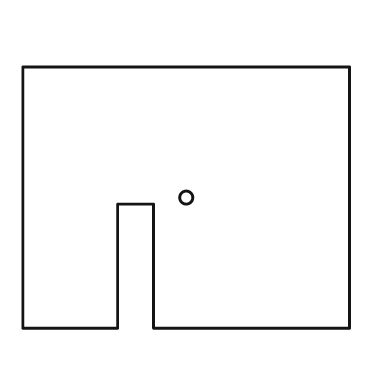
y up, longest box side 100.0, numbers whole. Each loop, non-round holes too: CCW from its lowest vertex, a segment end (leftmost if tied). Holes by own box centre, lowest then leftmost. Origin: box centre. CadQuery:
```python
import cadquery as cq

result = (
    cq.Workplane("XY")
    .moveTo(-50.0, -40.0)
    .lineTo(-21.0, -40.0)
    .lineTo(-21.0, -2.0)
    .lineTo(-10.0, -2.0)
    .lineTo(-10.0, -40.0)
    .lineTo(50.0, -40.0)
    .lineTo(50.0, 40.0)
    .lineTo(-50.0, 40.0)
    .close()
    .moveTo(0.0, 0.0)
    .circle(2.0)
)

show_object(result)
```